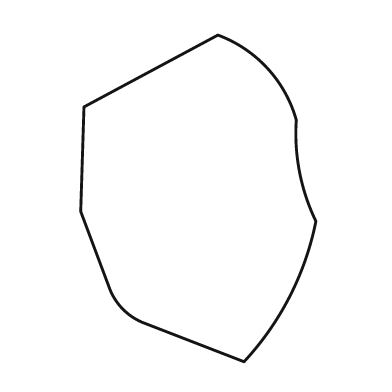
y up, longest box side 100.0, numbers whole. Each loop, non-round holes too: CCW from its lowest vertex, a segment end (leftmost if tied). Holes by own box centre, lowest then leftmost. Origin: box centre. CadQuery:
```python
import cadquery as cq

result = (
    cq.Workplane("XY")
    .moveTo(14.0, -50.0)
    .threePointArc((28.0, -30.0), (36.0, -7.0))
    .threePointArc((31.0, 8.0), (30.0, 24.0))
    .threePointArc((21.0, 40.0), (6.0, 50.0))
    .lineTo(-35.0, 28.0)
    .lineTo(-36.0, -4.0)
    .lineTo(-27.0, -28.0)
    .threePointArc((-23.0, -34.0), (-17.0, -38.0))
    .close()
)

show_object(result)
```